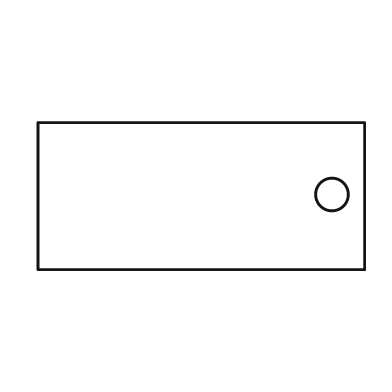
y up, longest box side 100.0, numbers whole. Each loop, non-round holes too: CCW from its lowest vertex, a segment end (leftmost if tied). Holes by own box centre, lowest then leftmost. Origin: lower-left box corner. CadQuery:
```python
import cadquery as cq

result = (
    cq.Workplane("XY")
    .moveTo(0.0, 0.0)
    .lineTo(100.0, 0.0)
    .lineTo(100.0, 45.0)
    .lineTo(0.0, 45.0)
    .close()
    .moveTo(90.0, 23.0)
    .circle(5.0)
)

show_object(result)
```